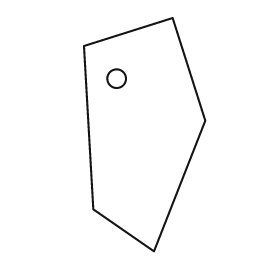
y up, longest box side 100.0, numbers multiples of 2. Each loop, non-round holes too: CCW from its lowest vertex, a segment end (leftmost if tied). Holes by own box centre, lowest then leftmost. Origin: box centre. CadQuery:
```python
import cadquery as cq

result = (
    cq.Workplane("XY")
    .moveTo(4.0, -50.0)
    .lineTo(26.0, 6.0)
    .lineTo(12.0, 50.0)
    .lineTo(-26.0, 38.0)
    .lineTo(-22.0, -32.0)
    .close()
    .moveTo(-12.0, 24.0)
    .circle(4.0)
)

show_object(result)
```